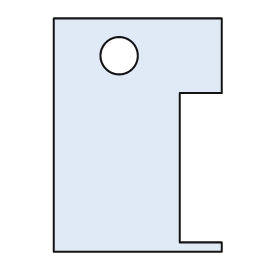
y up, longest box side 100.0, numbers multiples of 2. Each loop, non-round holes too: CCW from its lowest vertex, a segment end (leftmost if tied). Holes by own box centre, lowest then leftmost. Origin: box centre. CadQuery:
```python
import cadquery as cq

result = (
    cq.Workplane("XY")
    .moveTo(-36.0, -50.0)
    .lineTo(36.0, -50.0)
    .lineTo(36.0, -46.0)
    .lineTo(18.0, -46.0)
    .lineTo(18.0, 18.0)
    .lineTo(36.0, 18.0)
    .lineTo(36.0, 50.0)
    .lineTo(-36.0, 50.0)
    .close()
    .moveTo(-8.0, 34.0)
    .circle(8.0)
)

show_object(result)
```